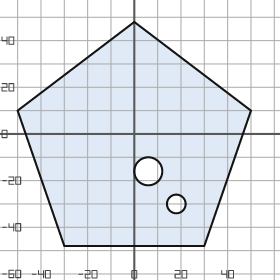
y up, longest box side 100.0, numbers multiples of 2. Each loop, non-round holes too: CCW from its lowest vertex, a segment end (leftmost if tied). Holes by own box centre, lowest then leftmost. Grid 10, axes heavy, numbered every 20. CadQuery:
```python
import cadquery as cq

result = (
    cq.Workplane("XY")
    .moveTo(-30.0, -48.0)
    .lineTo(30.0, -48.0)
    .lineTo(50.0, 10.0)
    .lineTo(0.0, 48.0)
    .lineTo(-50.0, 10.0)
    .close()
    .moveTo(18.0, -30.0)
    .circle(4.0)
    .moveTo(6.0, -16.0)
    .circle(6.0)
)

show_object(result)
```